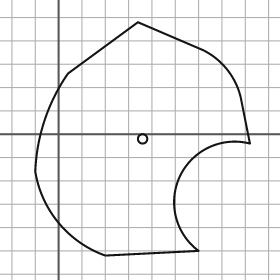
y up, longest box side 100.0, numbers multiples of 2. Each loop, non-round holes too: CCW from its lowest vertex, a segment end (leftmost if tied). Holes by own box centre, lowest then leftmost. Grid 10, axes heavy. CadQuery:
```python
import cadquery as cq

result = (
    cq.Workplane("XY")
    .moveTo(20.0, -52.0)
    .lineTo(60.0, -50.0)
    .threePointArc((52.0, -18.0), (82.0, -4.0))
    .lineTo(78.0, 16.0)
    .threePointArc((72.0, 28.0), (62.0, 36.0))
    .lineTo(34.0, 48.0)
    .lineTo(4.0, 26.0)
    .threePointArc((-6.0, 6.0), (-10.0, -16.0))
    .threePointArc((0.0, -38.0), (20.0, -52.0))
    .close()
    .moveTo(36.0, -2.0)
    .circle(2.0)
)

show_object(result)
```